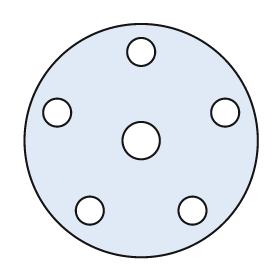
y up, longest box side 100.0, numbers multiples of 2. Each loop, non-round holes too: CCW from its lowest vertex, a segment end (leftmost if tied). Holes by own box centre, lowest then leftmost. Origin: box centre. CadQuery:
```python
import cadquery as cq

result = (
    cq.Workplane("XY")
    .moveTo(0.0, 0.0)
    .circle(50.0)
    .moveTo(-22.0, -30.0)
    .circle(6.0)
    .moveTo(22.0, -30.0)
    .circle(6.0)
    .moveTo(0.0, 0.0)
    .circle(8.0)
    .moveTo(-36.0, 12.0)
    .circle(6.0)
    .moveTo(36.0, 12.0)
    .circle(6.0)
    .moveTo(0.0, 38.0)
    .circle(6.0)
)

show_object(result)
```